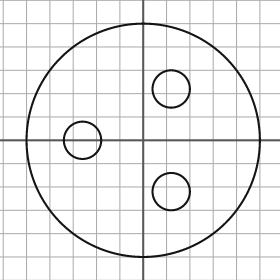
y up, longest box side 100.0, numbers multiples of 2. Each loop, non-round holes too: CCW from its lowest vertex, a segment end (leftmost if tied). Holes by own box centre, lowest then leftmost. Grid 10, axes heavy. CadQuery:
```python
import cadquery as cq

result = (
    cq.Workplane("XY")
    .moveTo(0.0, 0.0)
    .circle(50.0)
    .moveTo(12.0, -22.0)
    .circle(8.0)
    .moveTo(-26.0, 0.0)
    .circle(8.0)
    .moveTo(12.0, 22.0)
    .circle(8.0)
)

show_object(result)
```